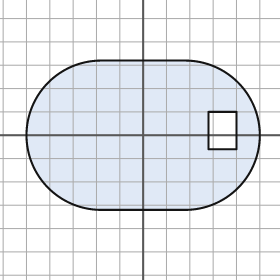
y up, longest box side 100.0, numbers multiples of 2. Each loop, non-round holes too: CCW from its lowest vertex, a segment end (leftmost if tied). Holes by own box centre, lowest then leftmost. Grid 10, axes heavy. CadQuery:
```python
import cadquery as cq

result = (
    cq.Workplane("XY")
    .moveTo(-18.0, -32.0)
    .lineTo(18.0, -32.0)
    .threePointArc((50.0, 0.0), (18.0, 32.0))
    .lineTo(-18.0, 32.0)
    .threePointArc((-50.0, 0.0), (-18.0, -32.0))
    .close()
    .moveTo(28.0, -6.0)
    .lineTo(40.0, -6.0)
    .lineTo(40.0, 10.0)
    .lineTo(28.0, 10.0)
    .close()
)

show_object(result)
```